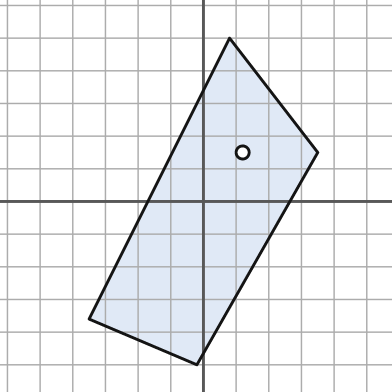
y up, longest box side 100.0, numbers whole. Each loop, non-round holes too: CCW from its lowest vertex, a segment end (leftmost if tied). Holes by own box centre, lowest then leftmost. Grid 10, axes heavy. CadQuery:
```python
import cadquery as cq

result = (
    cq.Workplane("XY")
    .moveTo(-2.0, -50.0)
    .lineTo(35.0, 15.0)
    .lineTo(8.0, 50.0)
    .lineTo(-35.0, -36.0)
    .close()
    .moveTo(12.0, 15.0)
    .circle(2.0)
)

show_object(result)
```